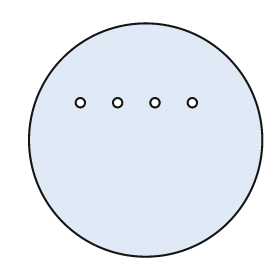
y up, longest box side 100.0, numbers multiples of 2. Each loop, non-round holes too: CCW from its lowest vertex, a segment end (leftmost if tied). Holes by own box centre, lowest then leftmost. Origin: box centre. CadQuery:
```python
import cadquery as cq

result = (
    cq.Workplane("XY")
    .moveTo(0.0, 0.0)
    .circle(50.0)
    .moveTo(-28.0, 16.0)
    .circle(2.0)
    .moveTo(-12.0, 16.0)
    .circle(2.0)
    .moveTo(4.0, 16.0)
    .circle(2.0)
    .moveTo(20.0, 16.0)
    .circle(2.0)
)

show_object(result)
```